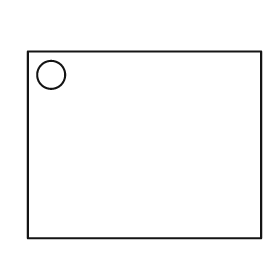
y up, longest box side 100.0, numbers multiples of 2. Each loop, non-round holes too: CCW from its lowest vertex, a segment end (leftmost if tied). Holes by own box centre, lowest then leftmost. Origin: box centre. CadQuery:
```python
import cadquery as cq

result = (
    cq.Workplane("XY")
    .moveTo(-50.0, -40.0)
    .lineTo(50.0, -40.0)
    .lineTo(50.0, 40.0)
    .lineTo(-50.0, 40.0)
    .close()
    .moveTo(-40.0, 30.0)
    .circle(6.0)
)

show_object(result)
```